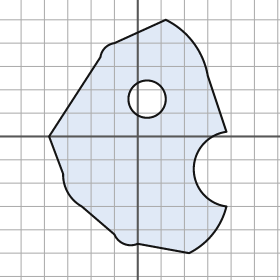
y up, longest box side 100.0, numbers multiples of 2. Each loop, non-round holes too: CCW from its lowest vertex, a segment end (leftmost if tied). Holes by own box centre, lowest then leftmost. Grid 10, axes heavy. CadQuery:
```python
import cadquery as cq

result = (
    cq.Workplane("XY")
    .moveTo(22.0, -50.0)
    .threePointArc((32.0, -42.0), (38.0, -30.0))
    .threePointArc((24.0, -14.0), (38.0, 2.0))
    .lineTo(30.0, 26.0)
    .threePointArc((24.0, 40.0), (12.0, 50.0))
    .lineTo(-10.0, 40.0)
    .threePointArc((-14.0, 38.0), (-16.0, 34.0))
    .lineTo(-38.0, 0.0)
    .lineTo(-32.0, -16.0)
    .threePointArc((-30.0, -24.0), (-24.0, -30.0))
    .lineTo(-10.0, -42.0)
    .threePointArc((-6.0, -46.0), (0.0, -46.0))
    .close()
    .moveTo(4.0, 16.0)
    .circle(8.0)
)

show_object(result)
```